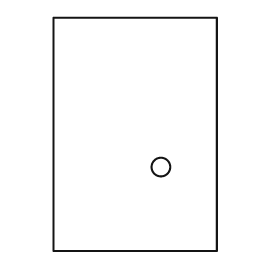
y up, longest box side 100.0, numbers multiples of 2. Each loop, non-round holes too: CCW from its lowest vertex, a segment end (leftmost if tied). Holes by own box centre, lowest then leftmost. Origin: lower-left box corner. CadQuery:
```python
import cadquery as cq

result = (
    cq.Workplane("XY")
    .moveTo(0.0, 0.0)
    .lineTo(70.0, 0.0)
    .lineTo(70.0, 100.0)
    .lineTo(0.0, 100.0)
    .close()
    .moveTo(46.0, 36.0)
    .circle(4.0)
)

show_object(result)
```